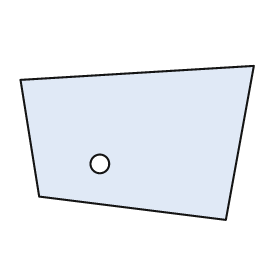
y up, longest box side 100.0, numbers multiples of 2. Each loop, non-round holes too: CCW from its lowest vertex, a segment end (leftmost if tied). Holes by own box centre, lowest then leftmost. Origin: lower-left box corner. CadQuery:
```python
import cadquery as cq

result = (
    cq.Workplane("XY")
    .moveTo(88.0, 0.0)
    .lineTo(100.0, 66.0)
    .lineTo(0.0, 60.0)
    .lineTo(8.0, 10.0)
    .close()
    .moveTo(34.0, 24.0)
    .circle(4.0)
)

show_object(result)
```